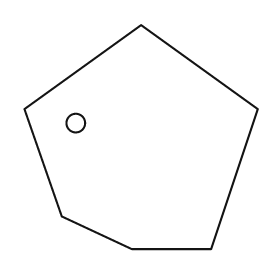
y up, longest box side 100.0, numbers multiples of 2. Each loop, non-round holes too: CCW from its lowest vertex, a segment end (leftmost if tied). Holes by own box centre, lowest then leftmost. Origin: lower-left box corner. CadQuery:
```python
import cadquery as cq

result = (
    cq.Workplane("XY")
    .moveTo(46.0, 0.0)
    .lineTo(80.0, 0.0)
    .lineTo(100.0, 60.0)
    .lineTo(50.0, 96.0)
    .lineTo(0.0, 60.0)
    .lineTo(16.0, 14.0)
    .close()
    .moveTo(22.0, 54.0)
    .circle(4.0)
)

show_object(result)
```